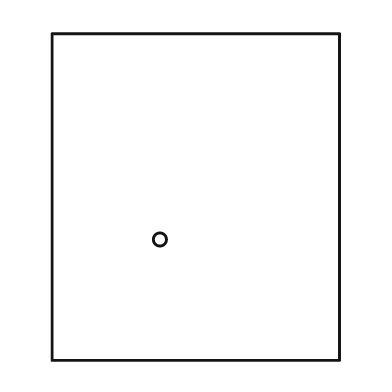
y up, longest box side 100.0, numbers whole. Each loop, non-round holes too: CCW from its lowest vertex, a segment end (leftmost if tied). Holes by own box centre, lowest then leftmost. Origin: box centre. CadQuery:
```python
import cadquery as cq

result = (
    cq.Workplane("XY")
    .moveTo(-44.0, -50.0)
    .lineTo(44.0, -50.0)
    .lineTo(44.0, 50.0)
    .lineTo(-44.0, 50.0)
    .close()
    .moveTo(-11.0, -13.0)
    .circle(2.0)
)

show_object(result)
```